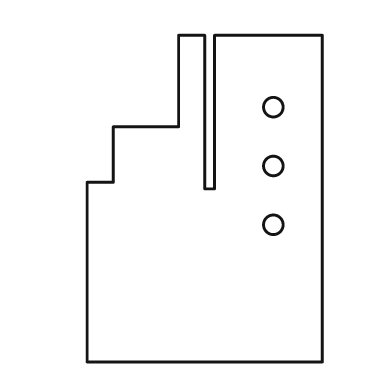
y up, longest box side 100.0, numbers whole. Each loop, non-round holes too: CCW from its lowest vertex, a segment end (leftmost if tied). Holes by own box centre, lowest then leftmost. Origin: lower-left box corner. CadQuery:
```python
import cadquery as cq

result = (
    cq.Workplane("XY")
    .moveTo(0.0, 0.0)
    .lineTo(72.0, 0.0)
    .lineTo(72.0, 100.0)
    .lineTo(39.0, 100.0)
    .lineTo(39.0, 53.0)
    .lineTo(36.0, 53.0)
    .lineTo(36.0, 100.0)
    .lineTo(28.0, 100.0)
    .lineTo(28.0, 72.0)
    .lineTo(8.0, 72.0)
    .lineTo(8.0, 55.0)
    .lineTo(0.0, 55.0)
    .close()
    .moveTo(57.0, 42.0)
    .circle(3.0)
    .moveTo(57.0, 60.0)
    .circle(3.0)
    .moveTo(57.0, 78.0)
    .circle(3.0)
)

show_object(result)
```